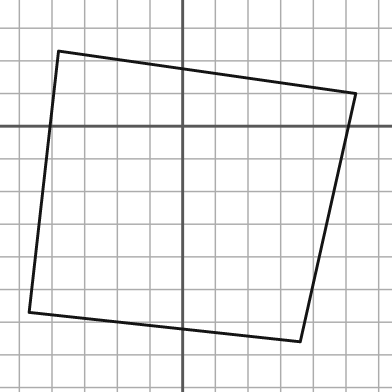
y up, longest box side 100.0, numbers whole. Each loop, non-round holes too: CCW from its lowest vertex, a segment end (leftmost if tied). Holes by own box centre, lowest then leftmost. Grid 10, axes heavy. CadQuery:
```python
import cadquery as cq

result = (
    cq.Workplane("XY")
    .moveTo(36.0, -66.0)
    .lineTo(53.0, 10.0)
    .lineTo(-38.0, 23.0)
    .lineTo(-47.0, -57.0)
    .close()
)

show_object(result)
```